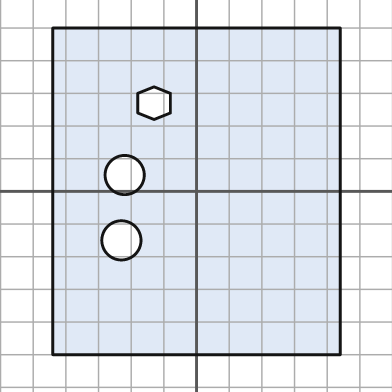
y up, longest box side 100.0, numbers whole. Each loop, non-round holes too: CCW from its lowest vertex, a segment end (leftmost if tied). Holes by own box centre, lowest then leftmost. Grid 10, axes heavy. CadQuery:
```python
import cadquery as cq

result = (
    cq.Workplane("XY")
    .moveTo(-44.0, -50.0)
    .lineTo(44.0, -50.0)
    .lineTo(44.0, 50.0)
    .lineTo(-44.0, 50.0)
    .close()
    .moveTo(-23.0, -15.0)
    .circle(6.0)
    .moveTo(-22.0, 5.0)
    .circle(6.0)
    .moveTo(-13.0, 22.0)
    .lineTo(-8.0, 24.0)
    .lineTo(-8.0, 30.0)
    .lineTo(-13.0, 32.0)
    .lineTo(-18.0, 30.0)
    .lineTo(-18.0, 24.0)
    .close()
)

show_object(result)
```